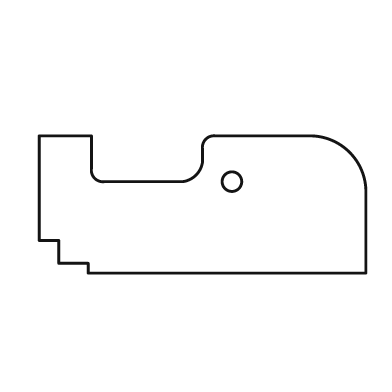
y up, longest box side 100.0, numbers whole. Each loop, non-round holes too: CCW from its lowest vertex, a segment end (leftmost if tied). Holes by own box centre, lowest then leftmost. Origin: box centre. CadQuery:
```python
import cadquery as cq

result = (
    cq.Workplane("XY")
    .moveTo(-35.0, -21.0)
    .lineTo(50.0, -21.0)
    .lineTo(50.0, 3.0)
    .threePointArc((45.0, 16.0), (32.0, 21.0))
    .lineTo(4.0, 21.0)
    .threePointArc((1.0, 20.0), (0.0, 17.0))
    .lineTo(0.0, 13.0)
    .threePointArc((-2.0, 9.0), (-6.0, 7.0))
    .lineTo(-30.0, 7.0)
    .threePointArc((-33.0, 8.0), (-34.0, 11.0))
    .lineTo(-34.0, 21.0)
    .lineTo(-50.0, 21.0)
    .lineTo(-50.0, -11.0)
    .lineTo(-44.0, -11.0)
    .lineTo(-44.0, -18.0)
    .lineTo(-35.0, -18.0)
    .close()
    .moveTo(9.0, 7.0)
    .circle(3.0)
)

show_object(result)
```